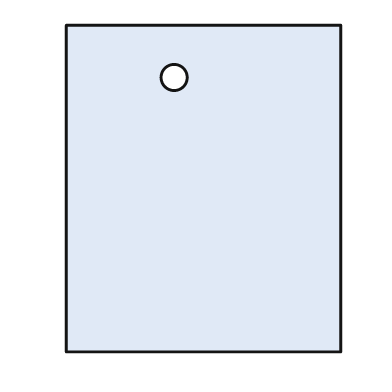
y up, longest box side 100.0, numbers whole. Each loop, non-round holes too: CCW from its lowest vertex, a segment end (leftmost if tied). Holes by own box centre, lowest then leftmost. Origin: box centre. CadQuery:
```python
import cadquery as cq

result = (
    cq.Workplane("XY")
    .moveTo(-42.0, -50.0)
    .lineTo(42.0, -50.0)
    .lineTo(42.0, 50.0)
    .lineTo(-42.0, 50.0)
    .close()
    .moveTo(-9.0, 34.0)
    .circle(4.0)
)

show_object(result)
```